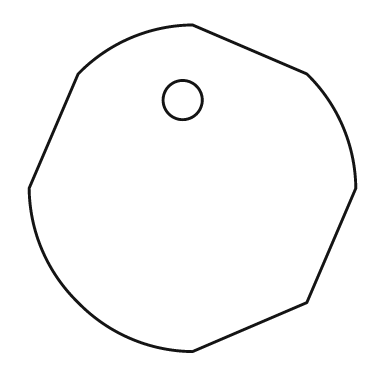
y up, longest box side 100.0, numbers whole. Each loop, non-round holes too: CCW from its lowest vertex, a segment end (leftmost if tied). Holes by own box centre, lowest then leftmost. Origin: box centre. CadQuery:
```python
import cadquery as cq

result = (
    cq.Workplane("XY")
    .moveTo(0.0, -50.0)
    .lineTo(35.0, -35.0)
    .lineTo(50.0, 0.0)
    .threePointArc((46.0, 19.0), (35.0, 35.0))
    .lineTo(0.0, 50.0)
    .threePointArc((-19.0, 46.0), (-35.0, 35.0))
    .lineTo(-50.0, 0.0)
    .threePointArc((-46.0, -19.0), (-35.0, -35.0))
    .threePointArc((-19.0, -46.0), (0.0, -50.0))
    .close()
    .moveTo(-3.0, 27.0)
    .circle(6.0)
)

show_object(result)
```